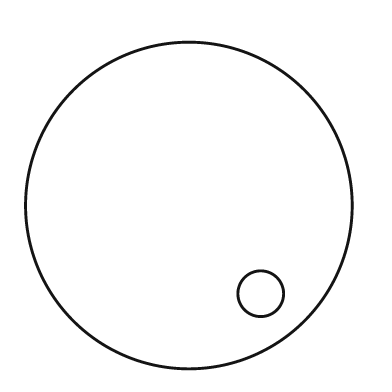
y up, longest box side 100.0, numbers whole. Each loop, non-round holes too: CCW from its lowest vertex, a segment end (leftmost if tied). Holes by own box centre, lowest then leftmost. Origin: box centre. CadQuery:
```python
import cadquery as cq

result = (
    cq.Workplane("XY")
    .moveTo(0.0, 0.0)
    .circle(50.0)
    .moveTo(22.0, -27.0)
    .circle(7.0)
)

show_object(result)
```